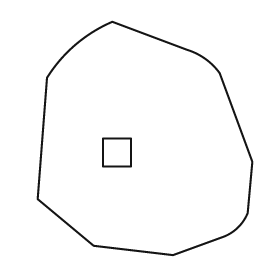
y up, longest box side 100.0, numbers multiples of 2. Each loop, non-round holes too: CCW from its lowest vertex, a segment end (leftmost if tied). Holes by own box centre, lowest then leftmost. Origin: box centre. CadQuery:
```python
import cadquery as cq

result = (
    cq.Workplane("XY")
    .moveTo(12.0, -50.0)
    .lineTo(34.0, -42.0)
    .threePointArc((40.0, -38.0), (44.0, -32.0))
    .lineTo(46.0, -10.0)
    .lineTo(32.0, 28.0)
    .threePointArc((26.0, 34.0), (18.0, 38.0))
    .lineTo(-14.0, 50.0)
    .threePointArc((-30.0, 40.0), (-42.0, 26.0))
    .lineTo(-46.0, -26.0)
    .lineTo(-22.0, -46.0)
    .close()
    .moveTo(-18.0, -12.0)
    .lineTo(-6.0, -12.0)
    .lineTo(-6.0, 0.0)
    .lineTo(-18.0, 0.0)
    .close()
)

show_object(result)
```